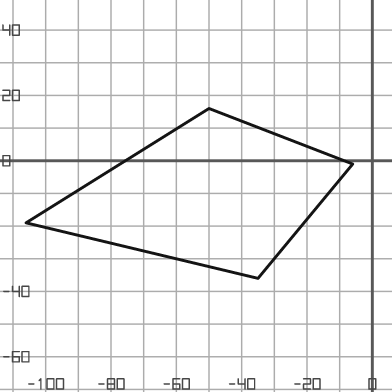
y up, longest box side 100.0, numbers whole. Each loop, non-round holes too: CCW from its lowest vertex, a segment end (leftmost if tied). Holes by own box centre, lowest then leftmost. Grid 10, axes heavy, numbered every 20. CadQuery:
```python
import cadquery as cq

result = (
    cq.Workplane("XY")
    .moveTo(-35.0, -36.0)
    .lineTo(-6.0, -1.0)
    .lineTo(-50.0, 16.0)
    .lineTo(-106.0, -19.0)
    .close()
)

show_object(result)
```